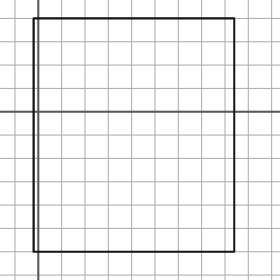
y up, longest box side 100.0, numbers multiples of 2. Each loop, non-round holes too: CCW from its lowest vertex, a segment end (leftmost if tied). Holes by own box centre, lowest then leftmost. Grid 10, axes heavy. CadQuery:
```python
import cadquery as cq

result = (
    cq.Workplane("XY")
    .moveTo(-2.0, -60.0)
    .lineTo(84.0, -60.0)
    .lineTo(84.0, 40.0)
    .lineTo(-2.0, 40.0)
    .close()
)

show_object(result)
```